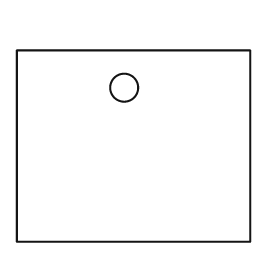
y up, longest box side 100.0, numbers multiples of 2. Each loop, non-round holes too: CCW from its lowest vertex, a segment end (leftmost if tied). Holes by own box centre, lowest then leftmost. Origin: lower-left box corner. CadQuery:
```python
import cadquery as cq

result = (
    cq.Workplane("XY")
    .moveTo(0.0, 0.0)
    .lineTo(100.0, 0.0)
    .lineTo(100.0, 82.0)
    .lineTo(0.0, 82.0)
    .close()
    .moveTo(46.0, 66.0)
    .circle(6.0)
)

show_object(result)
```